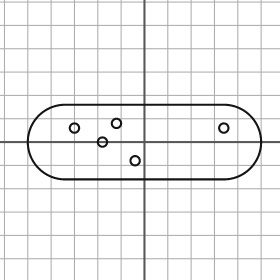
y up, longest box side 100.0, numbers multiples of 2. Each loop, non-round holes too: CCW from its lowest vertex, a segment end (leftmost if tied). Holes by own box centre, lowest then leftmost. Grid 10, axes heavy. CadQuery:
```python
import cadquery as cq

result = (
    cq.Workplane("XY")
    .moveTo(-34.0, -16.0)
    .lineTo(34.0, -16.0)
    .threePointArc((50.0, 0.0), (34.0, 16.0))
    .lineTo(-34.0, 16.0)
    .threePointArc((-50.0, 0.0), (-34.0, -16.0))
    .close()
    .moveTo(-4.0, -8.0)
    .circle(2.0)
    .moveTo(-18.0, 0.0)
    .circle(2.0)
    .moveTo(-30.0, 6.0)
    .circle(2.0)
    .moveTo(34.0, 6.0)
    .circle(2.0)
    .moveTo(-12.0, 8.0)
    .circle(2.0)
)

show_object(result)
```